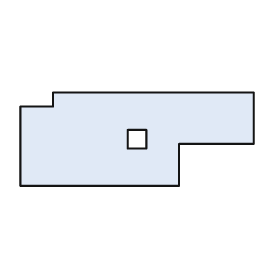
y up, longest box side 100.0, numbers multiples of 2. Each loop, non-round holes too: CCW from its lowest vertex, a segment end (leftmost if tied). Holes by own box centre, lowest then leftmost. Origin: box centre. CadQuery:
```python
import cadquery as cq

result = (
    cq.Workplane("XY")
    .moveTo(-50.0, -20.0)
    .lineTo(18.0, -20.0)
    .lineTo(18.0, -2.0)
    .lineTo(50.0, -2.0)
    .lineTo(50.0, 20.0)
    .lineTo(-36.0, 20.0)
    .lineTo(-36.0, 14.0)
    .lineTo(-50.0, 14.0)
    .close()
    .moveTo(-4.0, -4.0)
    .lineTo(4.0, -4.0)
    .lineTo(4.0, 4.0)
    .lineTo(-4.0, 4.0)
    .close()
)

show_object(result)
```